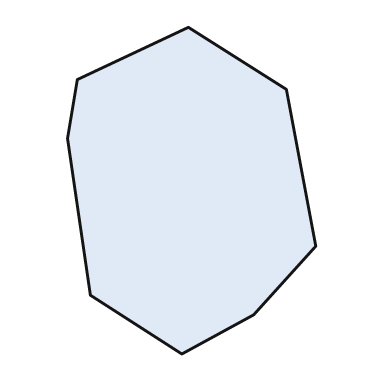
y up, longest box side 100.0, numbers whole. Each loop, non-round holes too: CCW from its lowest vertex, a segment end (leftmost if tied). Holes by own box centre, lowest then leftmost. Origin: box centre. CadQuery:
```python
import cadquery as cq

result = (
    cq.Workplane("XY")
    .moveTo(-3.0, -50.0)
    .lineTo(19.0, -38.0)
    .lineTo(38.0, -17.0)
    .lineTo(29.0, 31.0)
    .lineTo(-1.0, 50.0)
    .lineTo(-35.0, 34.0)
    .lineTo(-38.0, 16.0)
    .lineTo(-31.0, -32.0)
    .close()
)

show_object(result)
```